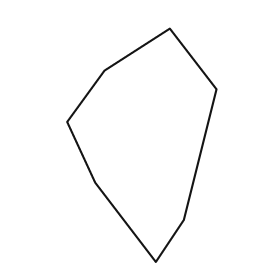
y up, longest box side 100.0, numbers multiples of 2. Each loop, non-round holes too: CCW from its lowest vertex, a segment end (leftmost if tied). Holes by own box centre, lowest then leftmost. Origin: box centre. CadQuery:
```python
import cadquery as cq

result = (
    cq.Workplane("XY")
    .moveTo(6.0, -50.0)
    .lineTo(18.0, -32.0)
    .lineTo(32.0, 24.0)
    .lineTo(12.0, 50.0)
    .lineTo(-16.0, 32.0)
    .lineTo(-32.0, 10.0)
    .lineTo(-20.0, -16.0)
    .close()
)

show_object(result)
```